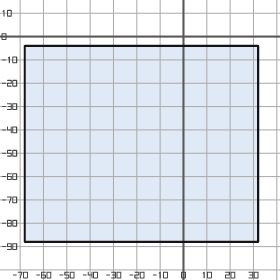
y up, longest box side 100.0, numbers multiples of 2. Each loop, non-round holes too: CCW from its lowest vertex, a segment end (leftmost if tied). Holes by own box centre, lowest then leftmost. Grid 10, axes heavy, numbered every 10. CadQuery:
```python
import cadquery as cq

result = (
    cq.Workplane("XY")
    .moveTo(-68.0, -88.0)
    .lineTo(32.0, -88.0)
    .lineTo(32.0, -4.0)
    .lineTo(-68.0, -4.0)
    .close()
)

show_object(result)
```